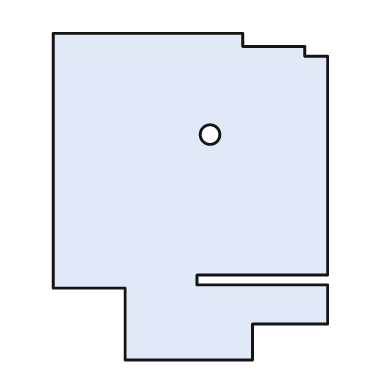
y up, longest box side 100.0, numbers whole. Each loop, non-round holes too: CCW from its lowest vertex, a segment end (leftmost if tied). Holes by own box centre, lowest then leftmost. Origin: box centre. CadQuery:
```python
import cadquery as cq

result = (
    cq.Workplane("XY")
    .moveTo(-20.0, -50.0)
    .lineTo(19.0, -50.0)
    .lineTo(19.0, -39.0)
    .lineTo(42.0, -39.0)
    .lineTo(42.0, -27.0)
    .lineTo(2.0, -27.0)
    .lineTo(2.0, -24.0)
    .lineTo(42.0, -24.0)
    .lineTo(42.0, 43.0)
    .lineTo(35.0, 43.0)
    .lineTo(35.0, 46.0)
    .lineTo(16.0, 46.0)
    .lineTo(16.0, 50.0)
    .lineTo(-42.0, 50.0)
    .lineTo(-42.0, -28.0)
    .lineTo(-20.0, -28.0)
    .close()
    .moveTo(6.0, 19.0)
    .circle(3.0)
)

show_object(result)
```